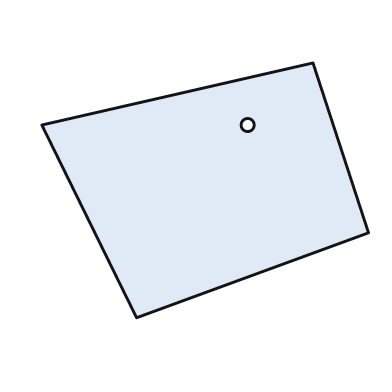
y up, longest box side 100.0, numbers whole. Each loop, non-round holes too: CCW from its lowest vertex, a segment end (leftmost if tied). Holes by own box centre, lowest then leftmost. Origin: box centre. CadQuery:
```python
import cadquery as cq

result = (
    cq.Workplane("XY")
    .moveTo(-21.0, -39.0)
    .lineTo(50.0, -13.0)
    .lineTo(33.0, 39.0)
    .lineTo(-50.0, 20.0)
    .close()
    .moveTo(13.0, 20.0)
    .circle(2.0)
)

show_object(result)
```